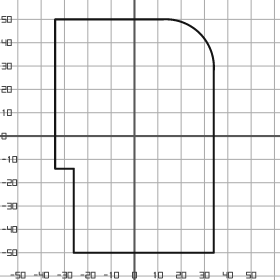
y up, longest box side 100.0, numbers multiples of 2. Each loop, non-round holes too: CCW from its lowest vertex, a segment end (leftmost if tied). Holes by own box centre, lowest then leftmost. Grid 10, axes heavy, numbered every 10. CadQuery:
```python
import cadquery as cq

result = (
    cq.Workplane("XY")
    .moveTo(-26.0, -50.0)
    .lineTo(34.0, -50.0)
    .lineTo(34.0, 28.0)
    .threePointArc((28.0, 44.0), (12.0, 50.0))
    .lineTo(-34.0, 50.0)
    .lineTo(-34.0, -14.0)
    .lineTo(-26.0, -14.0)
    .close()
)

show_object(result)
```